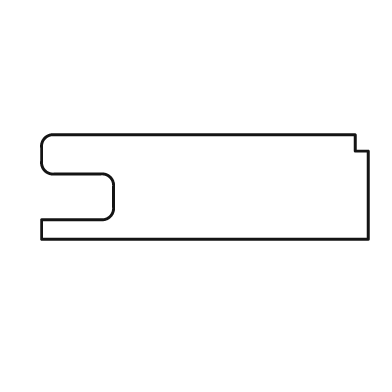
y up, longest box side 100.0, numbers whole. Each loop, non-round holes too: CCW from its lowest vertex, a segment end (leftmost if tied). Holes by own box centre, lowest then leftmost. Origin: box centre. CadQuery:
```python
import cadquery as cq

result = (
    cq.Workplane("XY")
    .moveTo(-50.0, -16.0)
    .lineTo(50.0, -16.0)
    .lineTo(50.0, 11.0)
    .lineTo(46.0, 11.0)
    .lineTo(46.0, 16.0)
    .lineTo(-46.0, 16.0)
    .threePointArc((-49.0, 15.0), (-50.0, 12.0))
    .lineTo(-50.0, 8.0)
    .threePointArc((-49.0, 5.0), (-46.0, 4.0))
    .lineTo(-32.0, 4.0)
    .threePointArc((-29.0, 3.0), (-28.0, 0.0))
    .lineTo(-28.0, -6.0)
    .threePointArc((-29.0, -9.0), (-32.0, -10.0))
    .lineTo(-50.0, -10.0)
    .close()
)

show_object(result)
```